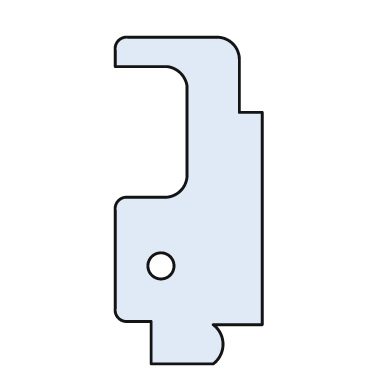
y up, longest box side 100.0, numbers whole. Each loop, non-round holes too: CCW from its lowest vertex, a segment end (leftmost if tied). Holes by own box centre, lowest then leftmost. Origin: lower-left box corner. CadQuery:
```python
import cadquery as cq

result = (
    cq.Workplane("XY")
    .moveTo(11.0, 0.0)
    .lineTo(30.0, 0.0)
    .threePointArc((33.0, 6.0), (30.0, 12.0))
    .lineTo(45.0, 12.0)
    .lineTo(45.0, 77.0)
    .lineTo(38.0, 77.0)
    .lineTo(38.0, 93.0)
    .threePointArc((36.0, 98.0), (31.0, 100.0))
    .lineTo(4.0, 100.0)
    .threePointArc((1.0, 99.0), (0.0, 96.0))
    .lineTo(0.0, 91.0)
    .lineTo(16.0, 91.0)
    .threePointArc((20.0, 89.0), (22.0, 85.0))
    .lineTo(22.0, 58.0)
    .threePointArc((20.0, 53.0), (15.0, 51.0))
    .lineTo(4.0, 51.0)
    .threePointArc((1.0, 50.0), (0.0, 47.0))
    .lineTo(0.0, 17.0)
    .threePointArc((1.0, 14.0), (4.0, 13.0))
    .lineTo(11.0, 13.0)
    .close()
    .moveTo(14.0, 30.0)
    .circle(4.0)
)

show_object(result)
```